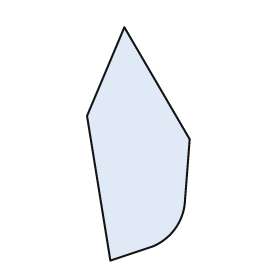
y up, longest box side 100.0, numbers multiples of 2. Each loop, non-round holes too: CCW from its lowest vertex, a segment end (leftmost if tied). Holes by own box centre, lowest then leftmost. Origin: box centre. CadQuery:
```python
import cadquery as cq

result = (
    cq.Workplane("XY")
    .moveTo(-12.0, -50.0)
    .lineTo(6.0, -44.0)
    .threePointArc((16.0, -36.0), (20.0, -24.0))
    .lineTo(22.0, 2.0)
    .lineTo(-6.0, 50.0)
    .lineTo(-22.0, 12.0)
    .close()
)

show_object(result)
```